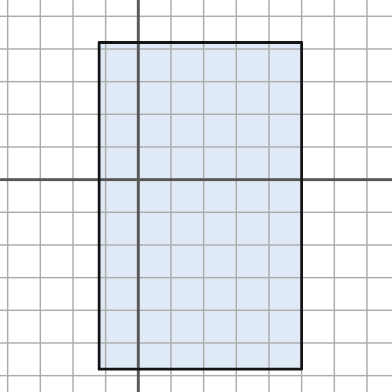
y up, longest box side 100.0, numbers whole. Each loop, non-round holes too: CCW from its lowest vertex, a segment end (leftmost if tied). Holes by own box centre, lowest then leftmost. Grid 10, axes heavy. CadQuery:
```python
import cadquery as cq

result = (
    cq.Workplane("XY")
    .moveTo(-12.0, -58.0)
    .lineTo(50.0, -58.0)
    .lineTo(50.0, 42.0)
    .lineTo(-12.0, 42.0)
    .close()
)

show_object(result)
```